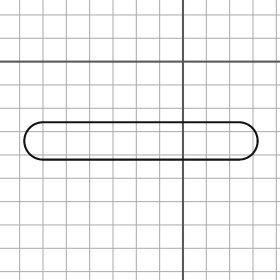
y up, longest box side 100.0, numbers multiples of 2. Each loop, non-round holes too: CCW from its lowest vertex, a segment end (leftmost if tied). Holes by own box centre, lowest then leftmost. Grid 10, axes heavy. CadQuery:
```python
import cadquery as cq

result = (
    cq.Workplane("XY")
    .moveTo(-60.0, -42.0)
    .lineTo(24.0, -42.0)
    .threePointArc((32.0, -34.0), (24.0, -26.0))
    .lineTo(-60.0, -26.0)
    .threePointArc((-68.0, -34.0), (-60.0, -42.0))
    .close()
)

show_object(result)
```